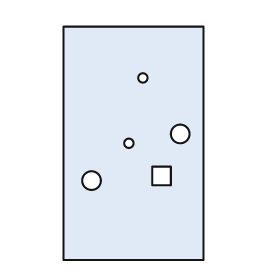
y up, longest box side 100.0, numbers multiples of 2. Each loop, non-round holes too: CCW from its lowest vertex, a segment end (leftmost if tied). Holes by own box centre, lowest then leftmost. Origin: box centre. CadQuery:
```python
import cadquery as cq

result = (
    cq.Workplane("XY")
    .moveTo(-30.0, -50.0)
    .lineTo(30.0, -50.0)
    .lineTo(30.0, 50.0)
    .lineTo(-30.0, 50.0)
    .close()
    .moveTo(-18.0, -16.0)
    .circle(4.0)
    .moveTo(8.0, -18.0)
    .lineTo(16.0, -18.0)
    .lineTo(16.0, -10.0)
    .lineTo(8.0, -10.0)
    .close()
    .moveTo(-2.0, 0.0)
    .circle(2.0)
    .moveTo(20.0, 4.0)
    .circle(4.0)
    .moveTo(4.0, 28.0)
    .circle(2.0)
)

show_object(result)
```